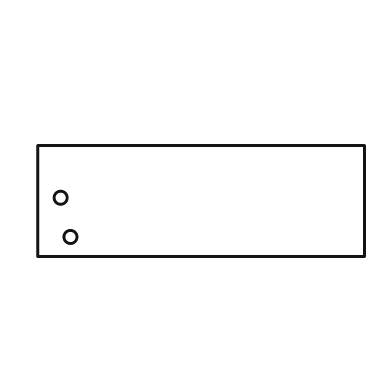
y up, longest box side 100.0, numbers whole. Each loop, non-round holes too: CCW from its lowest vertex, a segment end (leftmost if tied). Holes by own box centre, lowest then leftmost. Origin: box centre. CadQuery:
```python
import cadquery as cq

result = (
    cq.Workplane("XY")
    .moveTo(-50.0, -17.0)
    .lineTo(50.0, -17.0)
    .lineTo(50.0, 17.0)
    .lineTo(-50.0, 17.0)
    .close()
    .moveTo(-40.0, -11.0)
    .circle(2.0)
    .moveTo(-43.0, 1.0)
    .circle(2.0)
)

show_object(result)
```